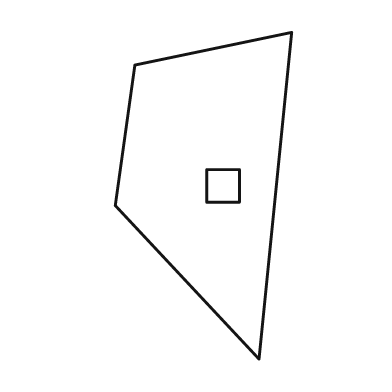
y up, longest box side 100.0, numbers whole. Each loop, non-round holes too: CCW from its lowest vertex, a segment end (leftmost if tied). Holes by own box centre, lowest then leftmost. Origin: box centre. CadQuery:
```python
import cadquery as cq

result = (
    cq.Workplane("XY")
    .moveTo(17.0, -50.0)
    .lineTo(27.0, 50.0)
    .lineTo(-21.0, 40.0)
    .lineTo(-27.0, -3.0)
    .close()
    .moveTo(1.0, -2.0)
    .lineTo(11.0, -2.0)
    .lineTo(11.0, 8.0)
    .lineTo(1.0, 8.0)
    .close()
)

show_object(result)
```